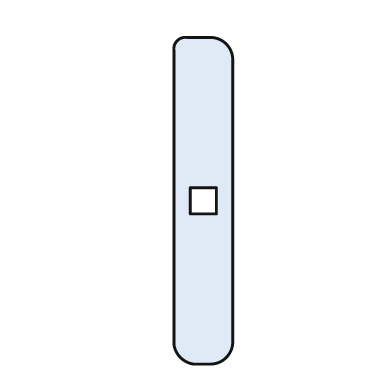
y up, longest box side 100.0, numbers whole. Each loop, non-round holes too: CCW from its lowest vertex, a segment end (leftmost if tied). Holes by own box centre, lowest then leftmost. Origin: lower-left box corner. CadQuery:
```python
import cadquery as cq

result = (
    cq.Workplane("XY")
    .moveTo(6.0, 0.0)
    .lineTo(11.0, 0.0)
    .threePointArc((16.0, 2.0), (18.0, 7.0))
    .lineTo(18.0, 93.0)
    .threePointArc((16.0, 98.0), (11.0, 100.0))
    .lineTo(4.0, 100.0)
    .threePointArc((1.0, 99.0), (0.0, 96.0))
    .lineTo(0.0, 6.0)
    .threePointArc((2.0, 2.0), (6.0, 0.0))
    .close()
    .moveTo(5.0, 46.0)
    .lineTo(13.0, 46.0)
    .lineTo(13.0, 54.0)
    .lineTo(5.0, 54.0)
    .close()
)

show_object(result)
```